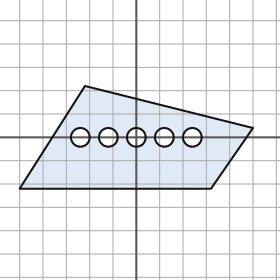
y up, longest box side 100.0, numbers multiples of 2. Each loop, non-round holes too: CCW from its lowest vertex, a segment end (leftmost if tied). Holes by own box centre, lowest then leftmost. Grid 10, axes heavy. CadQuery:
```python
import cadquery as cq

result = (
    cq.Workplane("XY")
    .moveTo(-50.0, -22.0)
    .lineTo(32.0, -22.0)
    .lineTo(50.0, 4.0)
    .lineTo(-22.0, 22.0)
    .close()
    .moveTo(-24.0, 0.0)
    .circle(4.0)
    .moveTo(-12.0, 0.0)
    .circle(4.0)
    .moveTo(0.0, 0.0)
    .circle(4.0)
    .moveTo(12.0, 0.0)
    .circle(4.0)
    .moveTo(24.0, 0.0)
    .circle(4.0)
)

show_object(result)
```